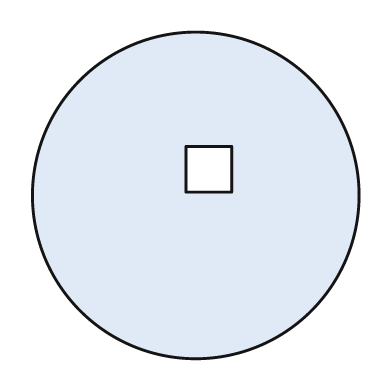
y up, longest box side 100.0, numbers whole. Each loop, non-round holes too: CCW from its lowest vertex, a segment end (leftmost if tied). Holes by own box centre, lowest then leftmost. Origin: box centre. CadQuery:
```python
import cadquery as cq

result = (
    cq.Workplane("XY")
    .moveTo(0.0, 0.0)
    .circle(50.0)
    .moveTo(-3.0, 1.0)
    .lineTo(11.0, 1.0)
    .lineTo(11.0, 15.0)
    .lineTo(-3.0, 15.0)
    .close()
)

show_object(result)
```